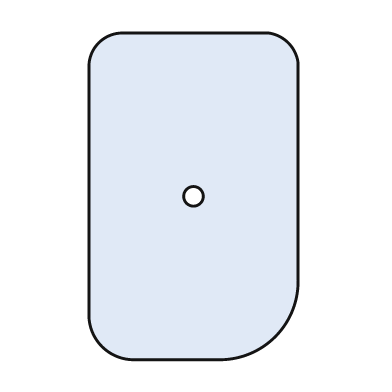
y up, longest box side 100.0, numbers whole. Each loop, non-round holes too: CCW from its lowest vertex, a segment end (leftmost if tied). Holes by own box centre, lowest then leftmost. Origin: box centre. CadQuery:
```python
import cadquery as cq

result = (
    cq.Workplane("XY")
    .moveTo(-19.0, -50.0)
    .lineTo(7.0, -50.0)
    .threePointArc((25.0, -43.0), (32.0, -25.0))
    .lineTo(32.0, 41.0)
    .threePointArc((29.0, 47.0), (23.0, 50.0))
    .lineTo(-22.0, 50.0)
    .threePointArc((-29.0, 47.0), (-32.0, 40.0))
    .lineTo(-32.0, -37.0)
    .threePointArc((-28.0, -46.0), (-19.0, -50.0))
    .close()
    .moveTo(0.0, 0.0)
    .circle(3.0)
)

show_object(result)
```